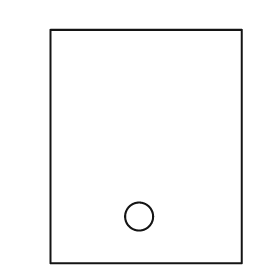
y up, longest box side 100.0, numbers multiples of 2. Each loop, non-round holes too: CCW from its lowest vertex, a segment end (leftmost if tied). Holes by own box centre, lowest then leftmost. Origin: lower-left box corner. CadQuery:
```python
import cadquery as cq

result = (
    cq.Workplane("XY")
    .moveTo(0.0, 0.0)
    .lineTo(82.0, 0.0)
    .lineTo(82.0, 100.0)
    .lineTo(0.0, 100.0)
    .close()
    .moveTo(38.0, 20.0)
    .circle(6.0)
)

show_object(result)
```